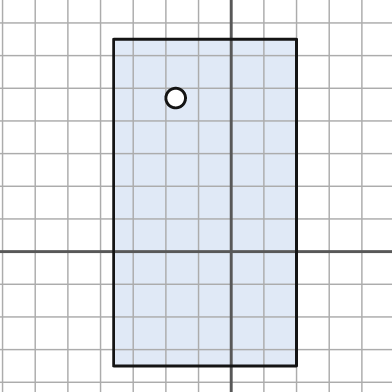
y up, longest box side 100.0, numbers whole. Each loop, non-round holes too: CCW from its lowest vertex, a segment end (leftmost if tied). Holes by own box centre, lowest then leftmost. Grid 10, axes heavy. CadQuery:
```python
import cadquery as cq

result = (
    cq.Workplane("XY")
    .moveTo(-36.0, -35.0)
    .lineTo(20.0, -35.0)
    .lineTo(20.0, 65.0)
    .lineTo(-36.0, 65.0)
    .close()
    .moveTo(-17.0, 47.0)
    .circle(3.0)
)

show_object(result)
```